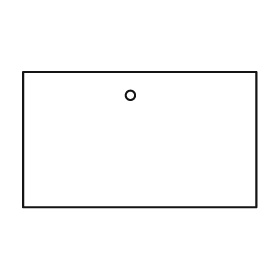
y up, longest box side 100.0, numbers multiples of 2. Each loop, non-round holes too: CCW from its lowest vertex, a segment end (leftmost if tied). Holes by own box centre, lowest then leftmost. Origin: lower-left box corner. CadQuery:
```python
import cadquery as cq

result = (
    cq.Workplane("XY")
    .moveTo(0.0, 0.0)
    .lineTo(100.0, 0.0)
    .lineTo(100.0, 58.0)
    .lineTo(0.0, 58.0)
    .close()
    .moveTo(46.0, 48.0)
    .circle(2.0)
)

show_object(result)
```